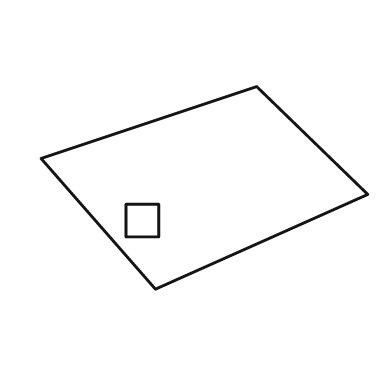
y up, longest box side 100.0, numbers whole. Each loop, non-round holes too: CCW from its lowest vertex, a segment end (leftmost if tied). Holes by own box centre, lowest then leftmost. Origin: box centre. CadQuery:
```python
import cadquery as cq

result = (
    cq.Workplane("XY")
    .moveTo(-15.0, -31.0)
    .lineTo(50.0, -2.0)
    .lineTo(16.0, 31.0)
    .lineTo(-50.0, 9.0)
    .close()
    .moveTo(-24.0, -15.0)
    .lineTo(-14.0, -15.0)
    .lineTo(-14.0, -5.0)
    .lineTo(-24.0, -5.0)
    .close()
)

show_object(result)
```